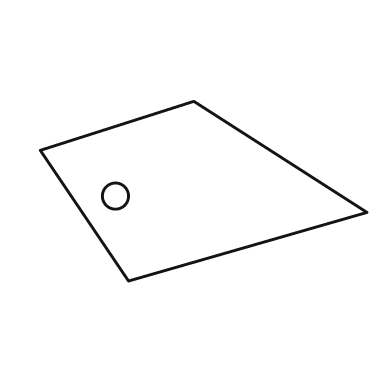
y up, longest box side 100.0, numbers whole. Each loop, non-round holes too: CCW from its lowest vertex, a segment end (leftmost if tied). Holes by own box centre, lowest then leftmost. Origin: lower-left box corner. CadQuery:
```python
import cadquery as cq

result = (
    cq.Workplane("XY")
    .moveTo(27.0, 0.0)
    .lineTo(100.0, 21.0)
    .lineTo(47.0, 55.0)
    .lineTo(0.0, 40.0)
    .close()
    .moveTo(23.0, 26.0)
    .circle(4.0)
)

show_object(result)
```